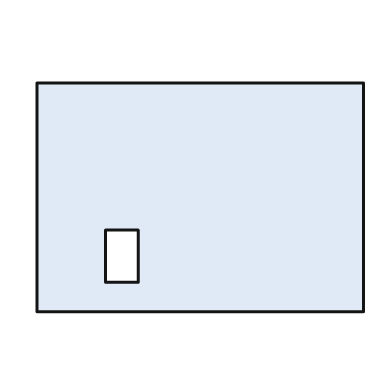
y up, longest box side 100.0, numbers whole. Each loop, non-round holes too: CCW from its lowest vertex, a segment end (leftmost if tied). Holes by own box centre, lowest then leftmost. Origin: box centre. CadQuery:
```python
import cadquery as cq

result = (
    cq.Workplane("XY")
    .moveTo(-50.0, -35.0)
    .lineTo(50.0, -35.0)
    .lineTo(50.0, 35.0)
    .lineTo(-50.0, 35.0)
    .close()
    .moveTo(-29.0, -26.0)
    .lineTo(-19.0, -26.0)
    .lineTo(-19.0, -10.0)
    .lineTo(-29.0, -10.0)
    .close()
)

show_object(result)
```